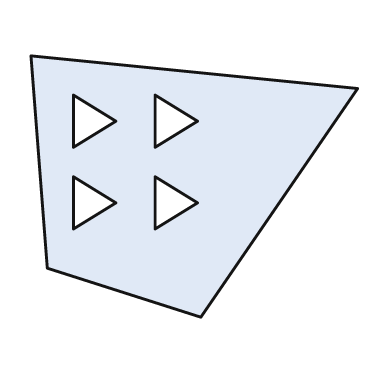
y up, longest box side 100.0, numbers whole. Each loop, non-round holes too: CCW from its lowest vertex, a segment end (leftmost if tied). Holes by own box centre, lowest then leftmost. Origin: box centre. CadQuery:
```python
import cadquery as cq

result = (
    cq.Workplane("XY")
    .moveTo(2.0, -40.0)
    .lineTo(50.0, 30.0)
    .lineTo(-50.0, 40.0)
    .lineTo(-45.0, -25.0)
    .close()
    .moveTo(-37.0, -13.0)
    .lineTo(-24.0, -5.0)
    .lineTo(-37.0, 3.0)
    .close()
    .moveTo(-12.0, -13.0)
    .lineTo(1.0, -5.0)
    .lineTo(-12.0, 3.0)
    .close()
    .moveTo(-37.0, 12.0)
    .lineTo(-24.0, 20.0)
    .lineTo(-37.0, 28.0)
    .close()
    .moveTo(-12.0, 12.0)
    .lineTo(1.0, 20.0)
    .lineTo(-12.0, 28.0)
    .close()
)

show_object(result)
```